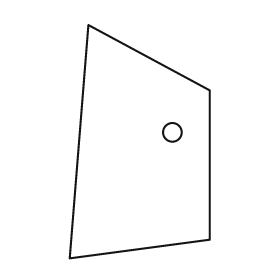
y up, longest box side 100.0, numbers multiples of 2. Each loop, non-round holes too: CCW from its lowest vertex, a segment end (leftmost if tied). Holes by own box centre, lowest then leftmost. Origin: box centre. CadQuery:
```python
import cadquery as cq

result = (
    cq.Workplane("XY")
    .moveTo(-30.0, -50.0)
    .lineTo(30.0, -42.0)
    .lineTo(30.0, 22.0)
    .lineTo(-22.0, 50.0)
    .close()
    .moveTo(14.0, 4.0)
    .circle(4.0)
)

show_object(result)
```